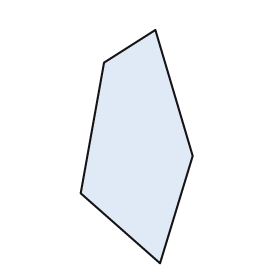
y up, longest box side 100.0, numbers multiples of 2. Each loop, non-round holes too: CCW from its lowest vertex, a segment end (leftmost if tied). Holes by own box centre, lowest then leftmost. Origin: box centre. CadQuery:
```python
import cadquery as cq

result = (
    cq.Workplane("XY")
    .moveTo(10.0, -50.0)
    .lineTo(24.0, -4.0)
    .lineTo(8.0, 50.0)
    .lineTo(-14.0, 36.0)
    .lineTo(-24.0, -20.0)
    .close()
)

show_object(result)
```